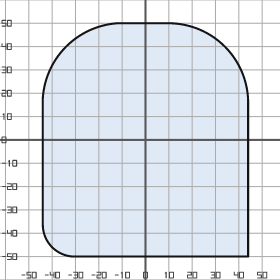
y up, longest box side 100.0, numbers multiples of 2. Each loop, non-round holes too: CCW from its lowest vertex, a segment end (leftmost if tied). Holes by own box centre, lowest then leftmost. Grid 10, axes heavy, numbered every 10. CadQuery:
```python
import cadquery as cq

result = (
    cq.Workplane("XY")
    .moveTo(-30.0, -50.0)
    .lineTo(44.0, -50.0)
    .lineTo(44.0, 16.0)
    .threePointArc((34.0, 40.0), (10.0, 50.0))
    .lineTo(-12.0, 50.0)
    .threePointArc((-34.0, 40.0), (-44.0, 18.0))
    .lineTo(-44.0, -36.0)
    .threePointArc((-40.0, -46.0), (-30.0, -50.0))
    .close()
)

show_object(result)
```